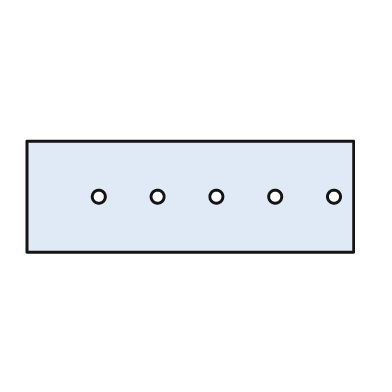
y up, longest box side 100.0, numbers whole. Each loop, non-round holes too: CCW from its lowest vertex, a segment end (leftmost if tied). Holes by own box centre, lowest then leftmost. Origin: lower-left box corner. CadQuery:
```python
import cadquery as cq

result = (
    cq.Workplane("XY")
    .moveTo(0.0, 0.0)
    .lineTo(100.0, 0.0)
    .lineTo(100.0, 34.0)
    .lineTo(0.0, 34.0)
    .close()
    .moveTo(22.0, 17.0)
    .circle(2.0)
    .moveTo(40.0, 17.0)
    .circle(2.0)
    .moveTo(58.0, 17.0)
    .circle(2.0)
    .moveTo(76.0, 17.0)
    .circle(2.0)
    .moveTo(94.0, 17.0)
    .circle(2.0)
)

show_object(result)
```